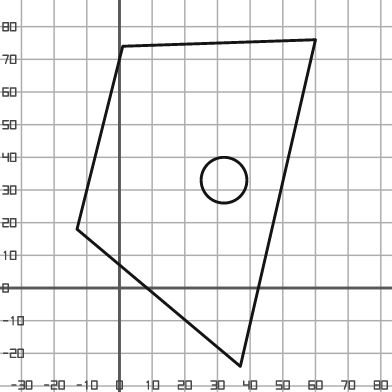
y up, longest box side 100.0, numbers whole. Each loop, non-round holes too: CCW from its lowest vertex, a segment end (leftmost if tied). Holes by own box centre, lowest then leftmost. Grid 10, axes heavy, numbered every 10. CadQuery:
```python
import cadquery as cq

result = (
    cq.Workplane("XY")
    .moveTo(37.0, -24.0)
    .lineTo(60.0, 76.0)
    .lineTo(1.0, 74.0)
    .lineTo(-13.0, 18.0)
    .close()
    .moveTo(32.0, 33.0)
    .circle(7.0)
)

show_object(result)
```